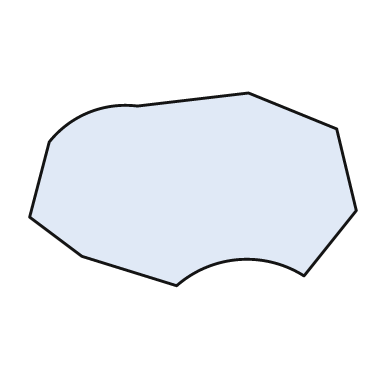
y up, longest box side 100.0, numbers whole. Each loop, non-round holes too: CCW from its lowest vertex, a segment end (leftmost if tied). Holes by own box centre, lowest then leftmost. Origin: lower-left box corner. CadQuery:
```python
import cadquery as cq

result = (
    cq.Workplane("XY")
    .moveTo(45.0, 0.0)
    .threePointArc((64.0, 8.0), (84.0, 3.0))
    .lineTo(100.0, 23.0)
    .lineTo(94.0, 48.0)
    .lineTo(67.0, 59.0)
    .lineTo(33.0, 55.0)
    .threePointArc((18.0, 53.0), (6.0, 44.0))
    .lineTo(0.0, 21.0)
    .lineTo(16.0, 9.0)
    .close()
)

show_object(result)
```